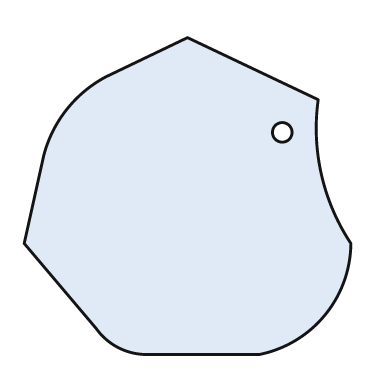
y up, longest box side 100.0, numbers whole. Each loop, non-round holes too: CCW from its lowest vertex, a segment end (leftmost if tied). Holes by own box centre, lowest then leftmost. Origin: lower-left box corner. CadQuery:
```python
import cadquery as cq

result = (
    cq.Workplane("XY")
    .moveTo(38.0, 0.0)
    .lineTo(72.0, 0.0)
    .threePointArc((92.0, 12.0), (100.0, 34.0))
    .threePointArc((91.0, 55.0), (90.0, 78.0))
    .lineTo(50.0, 97.0)
    .lineTo(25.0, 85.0)
    .threePointArc((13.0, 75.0), (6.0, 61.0))
    .lineTo(0.0, 34.0)
    .lineTo(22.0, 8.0)
    .threePointArc((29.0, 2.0), (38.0, 0.0))
    .close()
    .moveTo(79.0, 68.0)
    .circle(3.0)
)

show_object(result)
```